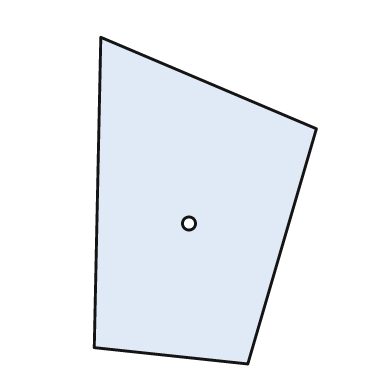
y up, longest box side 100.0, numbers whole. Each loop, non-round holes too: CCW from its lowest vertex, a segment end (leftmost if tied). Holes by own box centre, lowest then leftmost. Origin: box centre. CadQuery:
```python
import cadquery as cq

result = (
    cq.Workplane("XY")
    .moveTo(13.0, -50.0)
    .lineTo(34.0, 22.0)
    .lineTo(-32.0, 50.0)
    .lineTo(-34.0, -45.0)
    .close()
    .moveTo(-5.0, -7.0)
    .circle(2.0)
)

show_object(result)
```